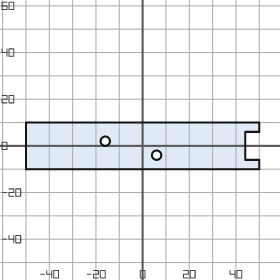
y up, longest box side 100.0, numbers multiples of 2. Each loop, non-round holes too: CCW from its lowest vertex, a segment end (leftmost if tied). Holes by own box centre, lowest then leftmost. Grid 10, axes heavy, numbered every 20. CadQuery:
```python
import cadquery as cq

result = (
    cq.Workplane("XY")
    .moveTo(-50.0, -10.0)
    .lineTo(50.0, -10.0)
    .lineTo(50.0, -6.0)
    .lineTo(44.0, -6.0)
    .lineTo(44.0, 6.0)
    .lineTo(50.0, 6.0)
    .lineTo(50.0, 10.0)
    .lineTo(-50.0, 10.0)
    .close()
    .moveTo(6.0, -4.0)
    .circle(2.0)
    .moveTo(-16.0, 2.0)
    .circle(2.0)
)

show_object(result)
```